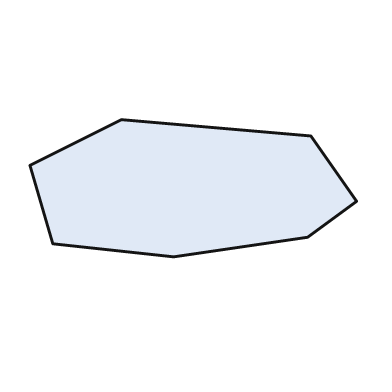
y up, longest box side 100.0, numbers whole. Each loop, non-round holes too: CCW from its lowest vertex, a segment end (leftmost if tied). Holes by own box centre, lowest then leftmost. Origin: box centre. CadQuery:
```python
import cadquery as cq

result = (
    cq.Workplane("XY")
    .moveTo(-6.0, -21.0)
    .lineTo(35.0, -15.0)
    .lineTo(50.0, -4.0)
    .lineTo(36.0, 16.0)
    .lineTo(-22.0, 21.0)
    .lineTo(-50.0, 7.0)
    .lineTo(-43.0, -17.0)
    .close()
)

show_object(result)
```